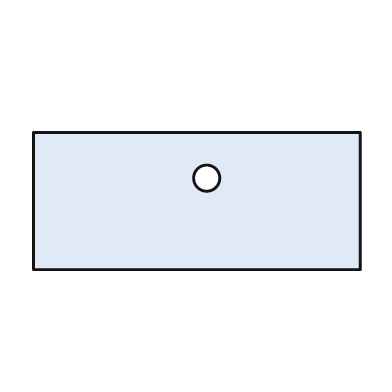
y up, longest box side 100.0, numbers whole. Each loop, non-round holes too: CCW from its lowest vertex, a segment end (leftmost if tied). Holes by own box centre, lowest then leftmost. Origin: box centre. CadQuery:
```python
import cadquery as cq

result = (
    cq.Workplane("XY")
    .moveTo(-50.0, -21.0)
    .lineTo(50.0, -21.0)
    .lineTo(50.0, 21.0)
    .lineTo(-50.0, 21.0)
    .close()
    .moveTo(3.0, 7.0)
    .circle(4.0)
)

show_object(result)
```